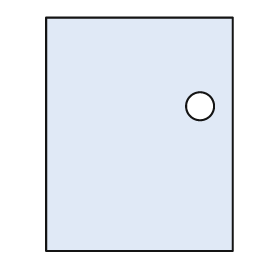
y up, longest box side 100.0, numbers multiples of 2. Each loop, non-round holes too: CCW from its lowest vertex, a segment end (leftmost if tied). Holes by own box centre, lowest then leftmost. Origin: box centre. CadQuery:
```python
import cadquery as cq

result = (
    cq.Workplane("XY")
    .moveTo(-40.0, -50.0)
    .lineTo(40.0, -50.0)
    .lineTo(40.0, 50.0)
    .lineTo(-40.0, 50.0)
    .close()
    .moveTo(26.0, 12.0)
    .circle(6.0)
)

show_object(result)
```